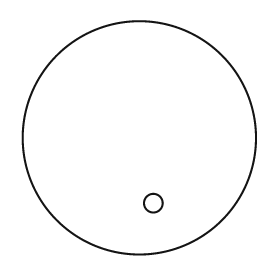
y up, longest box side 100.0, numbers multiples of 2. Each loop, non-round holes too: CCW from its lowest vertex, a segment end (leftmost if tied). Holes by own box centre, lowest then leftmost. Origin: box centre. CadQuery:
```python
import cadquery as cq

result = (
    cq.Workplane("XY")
    .moveTo(0.0, 0.0)
    .circle(50.0)
    .moveTo(6.0, -28.0)
    .circle(4.0)
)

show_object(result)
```